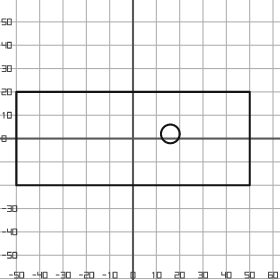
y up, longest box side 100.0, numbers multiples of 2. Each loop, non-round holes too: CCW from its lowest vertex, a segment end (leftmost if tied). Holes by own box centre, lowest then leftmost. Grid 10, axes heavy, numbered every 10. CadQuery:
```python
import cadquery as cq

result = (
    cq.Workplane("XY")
    .moveTo(-50.0, -20.0)
    .lineTo(50.0, -20.0)
    .lineTo(50.0, 20.0)
    .lineTo(-50.0, 20.0)
    .close()
    .moveTo(16.0, 2.0)
    .circle(4.0)
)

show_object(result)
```